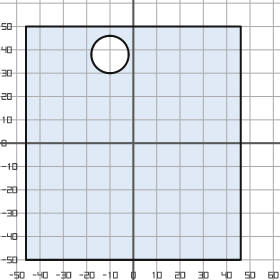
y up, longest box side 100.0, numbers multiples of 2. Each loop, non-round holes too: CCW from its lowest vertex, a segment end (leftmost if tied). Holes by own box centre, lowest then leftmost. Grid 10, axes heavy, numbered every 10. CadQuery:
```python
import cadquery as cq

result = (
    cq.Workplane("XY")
    .moveTo(-46.0, -50.0)
    .lineTo(46.0, -50.0)
    .lineTo(46.0, 50.0)
    .lineTo(-46.0, 50.0)
    .close()
    .moveTo(-10.0, 38.0)
    .circle(8.0)
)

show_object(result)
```